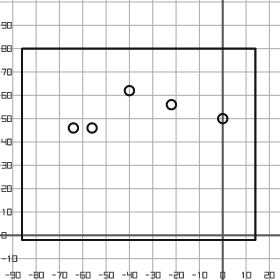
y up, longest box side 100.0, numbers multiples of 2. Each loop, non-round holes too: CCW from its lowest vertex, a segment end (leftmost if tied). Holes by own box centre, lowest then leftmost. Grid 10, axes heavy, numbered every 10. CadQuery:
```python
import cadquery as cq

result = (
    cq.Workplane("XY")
    .moveTo(-86.0, -2.0)
    .lineTo(14.0, -2.0)
    .lineTo(14.0, 80.0)
    .lineTo(-86.0, 80.0)
    .close()
    .moveTo(-64.0, 46.0)
    .circle(2.0)
    .moveTo(-56.0, 46.0)
    .circle(2.0)
    .moveTo(0.0, 50.0)
    .circle(2.0)
    .moveTo(-22.0, 56.0)
    .circle(2.0)
    .moveTo(-40.0, 62.0)
    .circle(2.0)
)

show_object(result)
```